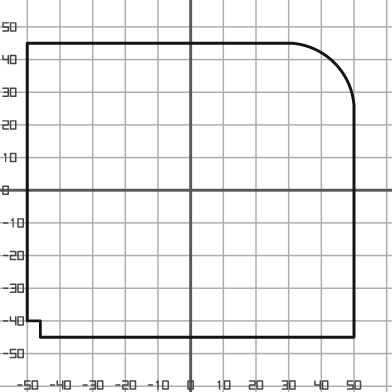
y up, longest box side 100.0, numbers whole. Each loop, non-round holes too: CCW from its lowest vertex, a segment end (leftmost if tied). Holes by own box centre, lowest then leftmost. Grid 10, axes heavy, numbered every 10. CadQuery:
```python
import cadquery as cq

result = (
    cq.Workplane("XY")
    .moveTo(-46.0, -45.0)
    .lineTo(50.0, -45.0)
    .lineTo(50.0, 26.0)
    .threePointArc((44.0, 39.0), (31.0, 45.0))
    .lineTo(-50.0, 45.0)
    .lineTo(-50.0, -40.0)
    .lineTo(-46.0, -40.0)
    .close()
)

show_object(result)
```